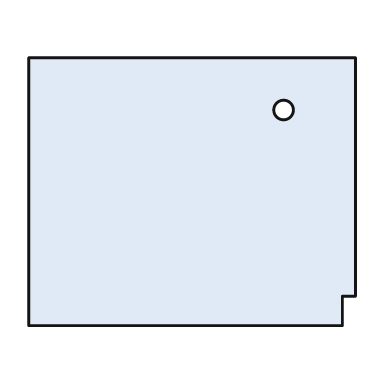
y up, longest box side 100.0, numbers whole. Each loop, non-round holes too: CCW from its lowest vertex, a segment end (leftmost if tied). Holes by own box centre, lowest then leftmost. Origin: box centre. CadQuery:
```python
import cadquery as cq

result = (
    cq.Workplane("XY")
    .moveTo(-50.0, -41.0)
    .lineTo(46.0, -41.0)
    .lineTo(46.0, -32.0)
    .lineTo(50.0, -32.0)
    .lineTo(50.0, 41.0)
    .lineTo(-50.0, 41.0)
    .close()
    .moveTo(28.0, 25.0)
    .circle(3.0)
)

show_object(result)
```